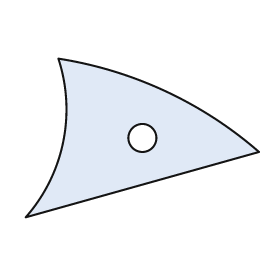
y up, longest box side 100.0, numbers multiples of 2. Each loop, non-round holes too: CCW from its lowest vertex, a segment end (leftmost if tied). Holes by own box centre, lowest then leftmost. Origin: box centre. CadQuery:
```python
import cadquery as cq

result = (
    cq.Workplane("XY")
    .moveTo(-50.0, -34.0)
    .lineTo(50.0, -6.0)
    .threePointArc((10.0, 20.0), (-36.0, 34.0))
    .threePointArc((-34.0, -2.0), (-50.0, -34.0))
    .close()
    .moveTo(0.0, 0.0)
    .circle(6.0)
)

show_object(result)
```